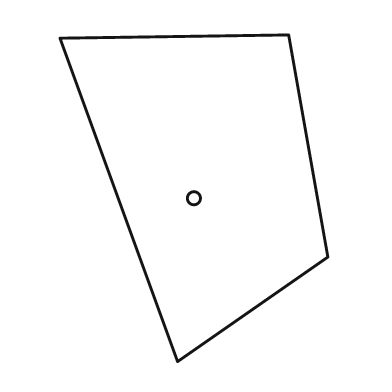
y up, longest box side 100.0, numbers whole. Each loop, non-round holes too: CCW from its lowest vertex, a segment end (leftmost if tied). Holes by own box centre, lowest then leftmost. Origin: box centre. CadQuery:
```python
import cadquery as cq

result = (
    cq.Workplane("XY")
    .moveTo(-5.0, -50.0)
    .lineTo(41.0, -18.0)
    .lineTo(29.0, 50.0)
    .lineTo(-41.0, 49.0)
    .close()
    .moveTo(0.0, 0.0)
    .circle(2.0)
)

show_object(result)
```